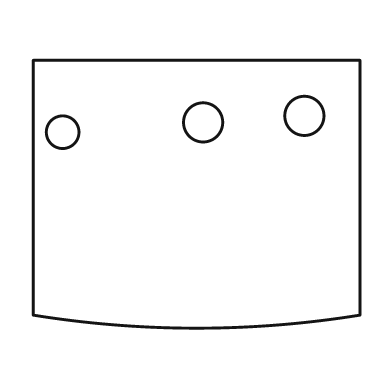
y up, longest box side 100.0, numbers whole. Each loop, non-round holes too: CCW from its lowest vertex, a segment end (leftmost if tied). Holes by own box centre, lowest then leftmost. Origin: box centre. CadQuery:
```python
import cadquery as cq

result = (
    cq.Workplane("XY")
    .moveTo(-50.0, -37.0)
    .threePointArc((0.0, -41.0), (50.0, -37.0))
    .lineTo(50.0, 41.0)
    .lineTo(-50.0, 41.0)
    .close()
    .moveTo(-41.0, 19.0)
    .circle(5.0)
    .moveTo(2.0, 22.0)
    .circle(6.0)
    .moveTo(33.0, 24.0)
    .circle(6.0)
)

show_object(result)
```